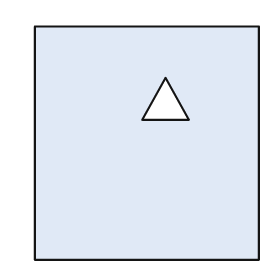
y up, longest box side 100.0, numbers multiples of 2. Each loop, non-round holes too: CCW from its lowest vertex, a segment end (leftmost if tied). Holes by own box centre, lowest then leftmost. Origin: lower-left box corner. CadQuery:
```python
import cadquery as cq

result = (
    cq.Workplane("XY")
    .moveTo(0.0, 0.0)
    .lineTo(96.0, 0.0)
    .lineTo(96.0, 100.0)
    .lineTo(0.0, 100.0)
    .close()
    .moveTo(46.0, 60.0)
    .lineTo(66.0, 60.0)
    .lineTo(56.0, 78.0)
    .close()
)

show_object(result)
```